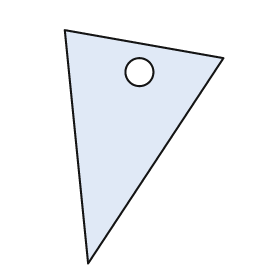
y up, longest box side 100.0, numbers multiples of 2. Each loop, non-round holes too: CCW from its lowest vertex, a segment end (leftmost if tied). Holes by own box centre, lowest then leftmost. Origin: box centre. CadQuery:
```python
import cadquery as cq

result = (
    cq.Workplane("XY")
    .moveTo(-24.0, -50.0)
    .lineTo(34.0, 38.0)
    .lineTo(-34.0, 50.0)
    .close()
    .moveTo(-2.0, 32.0)
    .circle(6.0)
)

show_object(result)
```